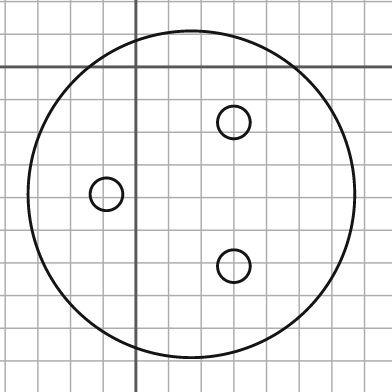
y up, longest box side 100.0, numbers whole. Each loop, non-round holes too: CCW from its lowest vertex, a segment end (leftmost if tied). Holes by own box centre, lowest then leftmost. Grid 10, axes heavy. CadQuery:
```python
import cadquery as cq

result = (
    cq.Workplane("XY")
    .moveTo(17.0, -39.0)
    .circle(50.0)
    .moveTo(30.0, -61.0)
    .circle(5.0)
    .moveTo(-9.0, -39.0)
    .circle(5.0)
    .moveTo(30.0, -17.0)
    .circle(5.0)
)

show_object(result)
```